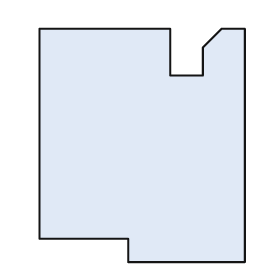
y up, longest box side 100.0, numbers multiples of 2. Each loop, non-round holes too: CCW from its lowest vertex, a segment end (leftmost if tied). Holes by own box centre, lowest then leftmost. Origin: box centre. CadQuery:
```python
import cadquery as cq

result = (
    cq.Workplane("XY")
    .moveTo(-6.0, -50.0)
    .lineTo(44.0, -50.0)
    .lineTo(44.0, 50.0)
    .lineTo(34.0, 50.0)
    .lineTo(26.0, 42.0)
    .lineTo(26.0, 30.0)
    .lineTo(12.0, 30.0)
    .lineTo(12.0, 50.0)
    .lineTo(-44.0, 50.0)
    .lineTo(-44.0, -40.0)
    .lineTo(-6.0, -40.0)
    .close()
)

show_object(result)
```